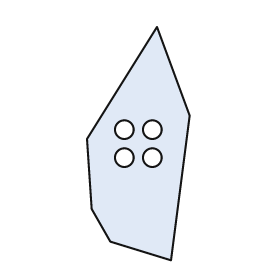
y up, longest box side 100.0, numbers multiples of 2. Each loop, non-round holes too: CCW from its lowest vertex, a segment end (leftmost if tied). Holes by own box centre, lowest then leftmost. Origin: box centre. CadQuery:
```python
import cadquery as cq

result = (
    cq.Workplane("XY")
    .moveTo(14.0, -50.0)
    .lineTo(22.0, 12.0)
    .lineTo(8.0, 50.0)
    .lineTo(-22.0, 2.0)
    .lineTo(-20.0, -28.0)
    .lineTo(-12.0, -42.0)
    .close()
    .moveTo(-6.0, -6.0)
    .circle(4.0)
    .moveTo(6.0, -6.0)
    .circle(4.0)
    .moveTo(-6.0, 6.0)
    .circle(4.0)
    .moveTo(6.0, 6.0)
    .circle(4.0)
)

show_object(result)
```